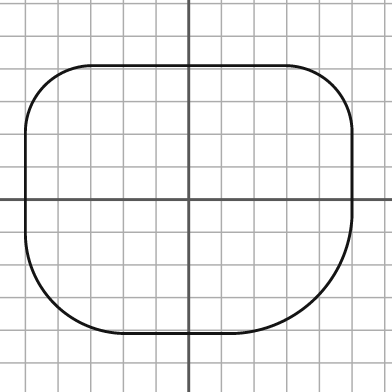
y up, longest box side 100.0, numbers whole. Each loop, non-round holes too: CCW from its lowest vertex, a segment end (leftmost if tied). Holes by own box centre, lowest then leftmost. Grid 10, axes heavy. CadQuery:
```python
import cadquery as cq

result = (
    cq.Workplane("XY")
    .moveTo(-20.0, -41.0)
    .lineTo(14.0, -41.0)
    .threePointArc((39.0, -30.0), (50.0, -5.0))
    .lineTo(50.0, 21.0)
    .threePointArc((44.0, 35.0), (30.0, 41.0))
    .lineTo(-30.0, 41.0)
    .threePointArc((-44.0, 35.0), (-50.0, 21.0))
    .lineTo(-50.0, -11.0)
    .threePointArc((-41.0, -32.0), (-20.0, -41.0))
    .close()
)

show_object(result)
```